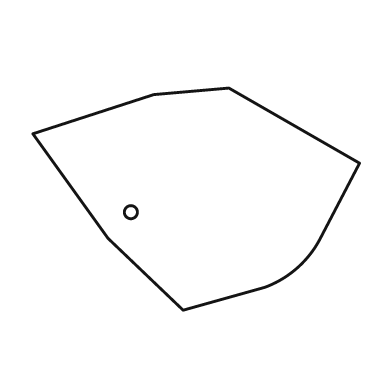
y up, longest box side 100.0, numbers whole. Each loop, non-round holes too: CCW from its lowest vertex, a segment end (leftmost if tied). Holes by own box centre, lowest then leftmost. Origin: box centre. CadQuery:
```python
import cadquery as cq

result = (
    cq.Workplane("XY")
    .moveTo(-4.0, -34.0)
    .lineTo(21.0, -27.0)
    .threePointArc((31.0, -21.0), (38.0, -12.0))
    .lineTo(50.0, 11.0)
    .lineTo(10.0, 34.0)
    .lineTo(-13.0, 32.0)
    .lineTo(-50.0, 20.0)
    .lineTo(-27.0, -12.0)
    .close()
    .moveTo(-20.0, -4.0)
    .circle(2.0)
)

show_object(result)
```